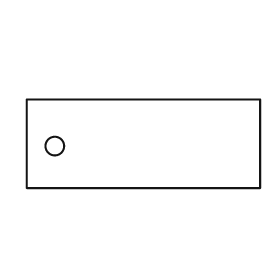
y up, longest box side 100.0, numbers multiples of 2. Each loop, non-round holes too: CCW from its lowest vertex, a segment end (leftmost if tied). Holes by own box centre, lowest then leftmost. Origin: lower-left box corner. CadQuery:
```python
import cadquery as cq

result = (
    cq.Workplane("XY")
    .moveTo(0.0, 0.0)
    .lineTo(100.0, 0.0)
    .lineTo(100.0, 38.0)
    .lineTo(0.0, 38.0)
    .close()
    .moveTo(12.0, 18.0)
    .circle(4.0)
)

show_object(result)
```